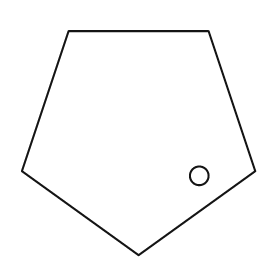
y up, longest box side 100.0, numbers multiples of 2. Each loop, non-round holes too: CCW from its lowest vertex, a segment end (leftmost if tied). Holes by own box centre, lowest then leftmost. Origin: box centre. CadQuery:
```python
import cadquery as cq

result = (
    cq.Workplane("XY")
    .moveTo(0.0, -48.0)
    .lineTo(50.0, -12.0)
    .lineTo(30.0, 48.0)
    .lineTo(-30.0, 48.0)
    .lineTo(-50.0, -12.0)
    .close()
    .moveTo(26.0, -14.0)
    .circle(4.0)
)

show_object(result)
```